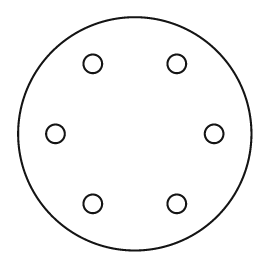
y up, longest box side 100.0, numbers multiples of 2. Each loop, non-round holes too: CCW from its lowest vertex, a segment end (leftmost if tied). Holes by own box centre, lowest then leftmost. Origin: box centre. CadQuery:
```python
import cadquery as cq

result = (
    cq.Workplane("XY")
    .moveTo(0.0, 0.0)
    .circle(50.0)
    .moveTo(-18.0, -30.0)
    .circle(4.0)
    .moveTo(18.0, -30.0)
    .circle(4.0)
    .moveTo(-34.0, 0.0)
    .circle(4.0)
    .moveTo(34.0, 0.0)
    .circle(4.0)
    .moveTo(-18.0, 30.0)
    .circle(4.0)
    .moveTo(18.0, 30.0)
    .circle(4.0)
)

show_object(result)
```